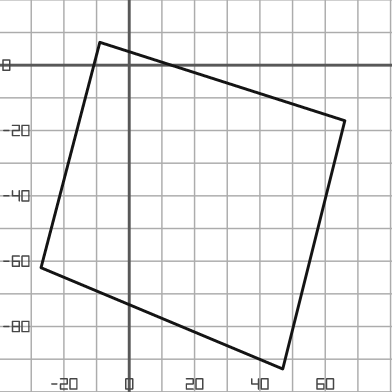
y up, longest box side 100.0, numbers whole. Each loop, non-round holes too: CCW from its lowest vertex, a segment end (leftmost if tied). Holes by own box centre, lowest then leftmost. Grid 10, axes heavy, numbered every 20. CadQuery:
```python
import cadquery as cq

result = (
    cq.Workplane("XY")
    .moveTo(47.0, -93.0)
    .lineTo(66.0, -17.0)
    .lineTo(-9.0, 7.0)
    .lineTo(-27.0, -62.0)
    .close()
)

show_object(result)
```